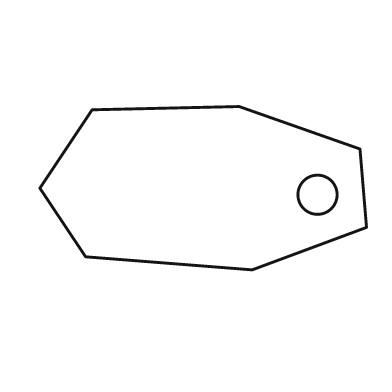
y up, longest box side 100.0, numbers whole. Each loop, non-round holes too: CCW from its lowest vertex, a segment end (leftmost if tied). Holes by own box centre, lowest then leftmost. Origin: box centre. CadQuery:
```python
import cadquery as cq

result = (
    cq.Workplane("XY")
    .moveTo(15.0, -25.0)
    .lineTo(50.0, -12.0)
    .lineTo(48.0, 12.0)
    .lineTo(11.0, 25.0)
    .lineTo(-34.0, 24.0)
    .lineTo(-50.0, 0.0)
    .lineTo(-36.0, -21.0)
    .close()
    .moveTo(35.0, -2.0)
    .circle(6.0)
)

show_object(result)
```